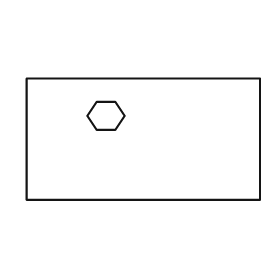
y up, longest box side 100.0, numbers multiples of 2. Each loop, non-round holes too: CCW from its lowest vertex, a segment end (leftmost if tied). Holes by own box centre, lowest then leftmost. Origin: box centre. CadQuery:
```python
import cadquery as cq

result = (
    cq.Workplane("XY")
    .moveTo(-50.0, -26.0)
    .lineTo(50.0, -26.0)
    .lineTo(50.0, 26.0)
    .lineTo(-50.0, 26.0)
    .close()
    .moveTo(-20.0, 4.0)
    .lineTo(-12.0, 4.0)
    .lineTo(-8.0, 10.0)
    .lineTo(-12.0, 16.0)
    .lineTo(-20.0, 16.0)
    .lineTo(-24.0, 10.0)
    .close()
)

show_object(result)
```